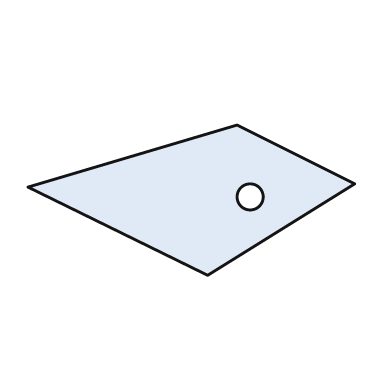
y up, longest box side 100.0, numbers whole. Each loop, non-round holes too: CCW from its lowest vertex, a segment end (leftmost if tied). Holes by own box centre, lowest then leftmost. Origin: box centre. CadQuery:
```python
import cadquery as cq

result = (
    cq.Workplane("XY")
    .moveTo(5.0, -23.0)
    .lineTo(50.0, 5.0)
    .lineTo(14.0, 23.0)
    .lineTo(-50.0, 4.0)
    .close()
    .moveTo(18.0, 1.0)
    .circle(4.0)
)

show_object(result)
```